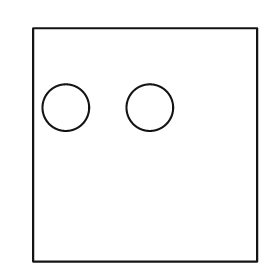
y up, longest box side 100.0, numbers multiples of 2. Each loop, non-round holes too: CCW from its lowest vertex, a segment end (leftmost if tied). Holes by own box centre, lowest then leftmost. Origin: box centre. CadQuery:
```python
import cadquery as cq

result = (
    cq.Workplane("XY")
    .moveTo(-48.0, -50.0)
    .lineTo(48.0, -50.0)
    .lineTo(48.0, 50.0)
    .lineTo(-48.0, 50.0)
    .close()
    .moveTo(-34.0, 16.0)
    .circle(10.0)
    .moveTo(2.0, 16.0)
    .circle(10.0)
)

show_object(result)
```